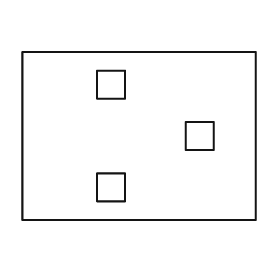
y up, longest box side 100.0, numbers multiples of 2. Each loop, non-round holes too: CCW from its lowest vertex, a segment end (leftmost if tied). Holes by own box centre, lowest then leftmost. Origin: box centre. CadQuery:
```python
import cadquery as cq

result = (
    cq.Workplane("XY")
    .moveTo(-50.0, -36.0)
    .lineTo(50.0, -36.0)
    .lineTo(50.0, 36.0)
    .lineTo(-50.0, 36.0)
    .close()
    .moveTo(-18.0, -28.0)
    .lineTo(-6.0, -28.0)
    .lineTo(-6.0, -16.0)
    .lineTo(-18.0, -16.0)
    .close()
    .moveTo(20.0, -6.0)
    .lineTo(32.0, -6.0)
    .lineTo(32.0, 6.0)
    .lineTo(20.0, 6.0)
    .close()
    .moveTo(-18.0, 16.0)
    .lineTo(-6.0, 16.0)
    .lineTo(-6.0, 28.0)
    .lineTo(-18.0, 28.0)
    .close()
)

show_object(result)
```